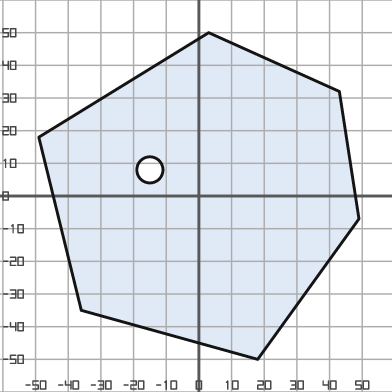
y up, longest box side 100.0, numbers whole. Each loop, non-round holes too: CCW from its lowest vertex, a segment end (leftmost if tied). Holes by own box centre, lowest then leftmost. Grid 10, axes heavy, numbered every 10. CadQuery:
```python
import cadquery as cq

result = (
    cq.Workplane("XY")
    .moveTo(18.0, -50.0)
    .lineTo(49.0, -7.0)
    .lineTo(43.0, 32.0)
    .lineTo(3.0, 50.0)
    .lineTo(-49.0, 18.0)
    .lineTo(-36.0, -35.0)
    .close()
    .moveTo(-15.0, 8.0)
    .circle(4.0)
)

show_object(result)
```